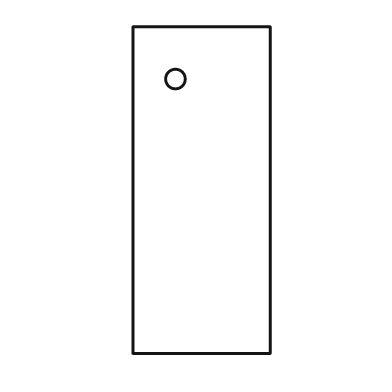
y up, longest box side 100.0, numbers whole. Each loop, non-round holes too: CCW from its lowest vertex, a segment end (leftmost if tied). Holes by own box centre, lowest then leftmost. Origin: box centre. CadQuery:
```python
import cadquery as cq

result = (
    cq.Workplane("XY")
    .moveTo(-21.0, -50.0)
    .lineTo(21.0, -50.0)
    .lineTo(21.0, 50.0)
    .lineTo(-21.0, 50.0)
    .close()
    .moveTo(-8.0, 34.0)
    .circle(3.0)
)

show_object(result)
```